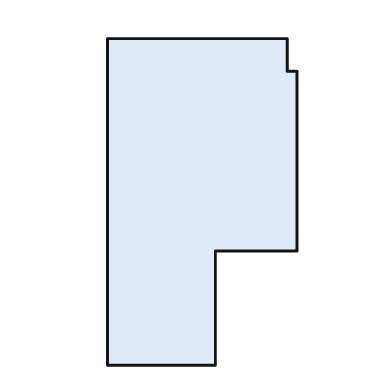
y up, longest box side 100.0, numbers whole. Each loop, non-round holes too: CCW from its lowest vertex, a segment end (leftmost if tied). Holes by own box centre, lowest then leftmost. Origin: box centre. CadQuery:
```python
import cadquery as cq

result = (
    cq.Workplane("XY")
    .moveTo(-29.0, -50.0)
    .lineTo(4.0, -50.0)
    .lineTo(4.0, -15.0)
    .lineTo(29.0, -15.0)
    .lineTo(29.0, 40.0)
    .lineTo(26.0, 40.0)
    .lineTo(26.0, 50.0)
    .lineTo(-29.0, 50.0)
    .close()
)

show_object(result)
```